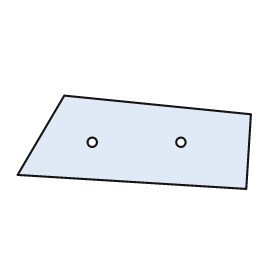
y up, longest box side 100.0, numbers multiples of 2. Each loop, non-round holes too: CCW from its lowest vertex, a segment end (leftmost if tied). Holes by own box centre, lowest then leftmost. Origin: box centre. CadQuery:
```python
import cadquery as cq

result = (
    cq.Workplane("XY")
    .moveTo(48.0, -20.0)
    .lineTo(50.0, 12.0)
    .lineTo(-30.0, 20.0)
    .lineTo(-50.0, -14.0)
    .close()
    .moveTo(-18.0, 0.0)
    .circle(2.0)
    .moveTo(20.0, 0.0)
    .circle(2.0)
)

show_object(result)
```